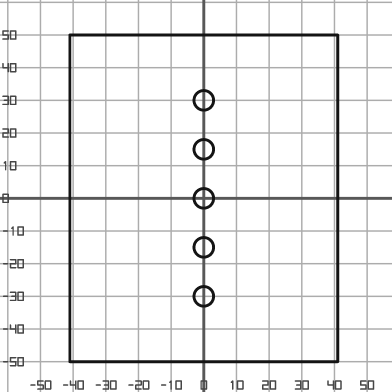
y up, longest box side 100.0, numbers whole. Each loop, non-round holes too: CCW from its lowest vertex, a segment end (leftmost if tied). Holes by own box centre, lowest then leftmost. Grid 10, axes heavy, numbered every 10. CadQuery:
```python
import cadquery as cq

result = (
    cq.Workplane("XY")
    .moveTo(-41.0, -50.0)
    .lineTo(41.0, -50.0)
    .lineTo(41.0, 50.0)
    .lineTo(-41.0, 50.0)
    .close()
    .moveTo(0.0, -30.0)
    .circle(3.0)
    .moveTo(0.0, -15.0)
    .circle(3.0)
    .moveTo(0.0, 0.0)
    .circle(3.0)
    .moveTo(0.0, 15.0)
    .circle(3.0)
    .moveTo(0.0, 30.0)
    .circle(3.0)
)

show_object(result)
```